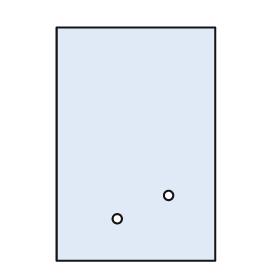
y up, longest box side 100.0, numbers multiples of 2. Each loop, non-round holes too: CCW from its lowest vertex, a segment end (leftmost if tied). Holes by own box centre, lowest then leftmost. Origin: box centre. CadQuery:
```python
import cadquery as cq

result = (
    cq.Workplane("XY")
    .moveTo(-34.0, -50.0)
    .lineTo(34.0, -50.0)
    .lineTo(34.0, 50.0)
    .lineTo(-34.0, 50.0)
    .close()
    .moveTo(-8.0, -32.0)
    .circle(2.0)
    .moveTo(14.0, -22.0)
    .circle(2.0)
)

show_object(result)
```